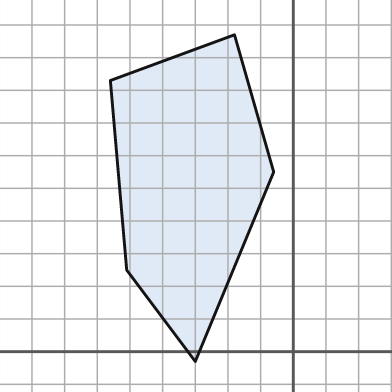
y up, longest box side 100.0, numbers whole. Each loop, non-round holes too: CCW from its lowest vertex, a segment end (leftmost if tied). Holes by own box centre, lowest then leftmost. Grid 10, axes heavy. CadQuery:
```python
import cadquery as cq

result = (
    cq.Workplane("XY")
    .moveTo(-30.0, -3.0)
    .lineTo(-6.0, 55.0)
    .lineTo(-18.0, 97.0)
    .lineTo(-56.0, 83.0)
    .lineTo(-51.0, 25.0)
    .close()
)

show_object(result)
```